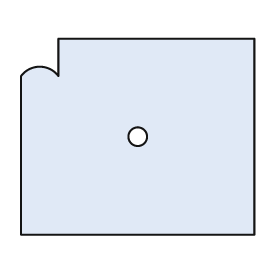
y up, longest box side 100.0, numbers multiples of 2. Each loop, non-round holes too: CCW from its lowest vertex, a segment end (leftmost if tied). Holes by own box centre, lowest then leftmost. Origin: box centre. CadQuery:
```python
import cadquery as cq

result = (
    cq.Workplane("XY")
    .moveTo(-50.0, -42.0)
    .lineTo(50.0, -42.0)
    .lineTo(50.0, 42.0)
    .lineTo(-34.0, 42.0)
    .lineTo(-34.0, 26.0)
    .threePointArc((-42.0, 30.0), (-50.0, 26.0))
    .close()
    .moveTo(0.0, 0.0)
    .circle(4.0)
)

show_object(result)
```